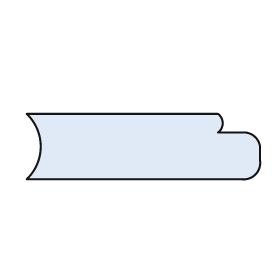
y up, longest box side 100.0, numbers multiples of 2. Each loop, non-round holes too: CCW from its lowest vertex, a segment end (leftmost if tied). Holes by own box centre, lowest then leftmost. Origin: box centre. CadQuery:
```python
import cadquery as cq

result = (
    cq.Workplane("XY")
    .moveTo(-50.0, -14.0)
    .lineTo(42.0, -14.0)
    .threePointArc((48.0, -12.0), (50.0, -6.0))
    .lineTo(50.0, 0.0)
    .threePointArc((48.0, 4.0), (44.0, 6.0))
    .lineTo(32.0, 6.0)
    .threePointArc((34.0, 10.0), (32.0, 14.0))
    .lineTo(-50.0, 14.0)
    .threePointArc((-44.0, 0.0), (-50.0, -14.0))
    .close()
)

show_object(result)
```